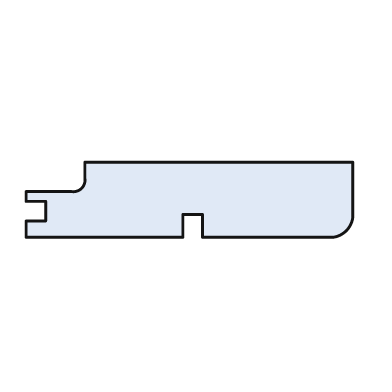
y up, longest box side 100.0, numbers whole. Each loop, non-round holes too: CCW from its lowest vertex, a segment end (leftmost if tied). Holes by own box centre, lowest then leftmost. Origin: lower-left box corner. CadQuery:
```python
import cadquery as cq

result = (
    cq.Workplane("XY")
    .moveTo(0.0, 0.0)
    .lineTo(48.0, 0.0)
    .lineTo(48.0, 7.0)
    .lineTo(54.0, 7.0)
    .lineTo(54.0, 0.0)
    .lineTo(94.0, 0.0)
    .threePointArc((98.0, 2.0), (100.0, 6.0))
    .lineTo(100.0, 23.0)
    .lineTo(18.0, 23.0)
    .lineTo(18.0, 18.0)
    .threePointArc((17.0, 15.0), (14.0, 14.0))
    .lineTo(0.0, 14.0)
    .lineTo(0.0, 11.0)
    .lineTo(6.0, 11.0)
    .lineTo(6.0, 5.0)
    .lineTo(0.0, 5.0)
    .close()
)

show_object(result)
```